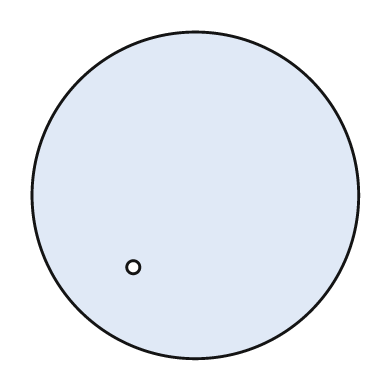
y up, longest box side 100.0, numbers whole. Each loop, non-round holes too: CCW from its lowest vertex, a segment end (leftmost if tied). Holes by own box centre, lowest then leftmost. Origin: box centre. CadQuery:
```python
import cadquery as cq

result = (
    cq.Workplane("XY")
    .moveTo(0.0, 0.0)
    .circle(50.0)
    .moveTo(-19.0, -22.0)
    .circle(2.0)
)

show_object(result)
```